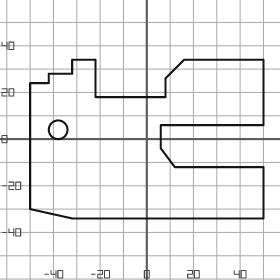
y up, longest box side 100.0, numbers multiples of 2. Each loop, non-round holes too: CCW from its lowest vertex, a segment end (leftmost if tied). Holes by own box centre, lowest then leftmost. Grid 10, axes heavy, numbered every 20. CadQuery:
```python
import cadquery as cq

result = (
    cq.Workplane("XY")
    .moveTo(-32.0, -34.0)
    .lineTo(50.0, -34.0)
    .lineTo(50.0, -12.0)
    .lineTo(12.0, -12.0)
    .lineTo(6.0, -4.0)
    .lineTo(6.0, 6.0)
    .lineTo(50.0, 6.0)
    .lineTo(50.0, 34.0)
    .lineTo(16.0, 34.0)
    .lineTo(8.0, 26.0)
    .lineTo(8.0, 18.0)
    .lineTo(-22.0, 18.0)
    .lineTo(-22.0, 34.0)
    .lineTo(-32.0, 34.0)
    .lineTo(-32.0, 28.0)
    .lineTo(-42.0, 28.0)
    .lineTo(-42.0, 24.0)
    .lineTo(-50.0, 24.0)
    .lineTo(-50.0, -30.0)
    .close()
    .moveTo(-38.0, 4.0)
    .circle(4.0)
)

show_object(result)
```